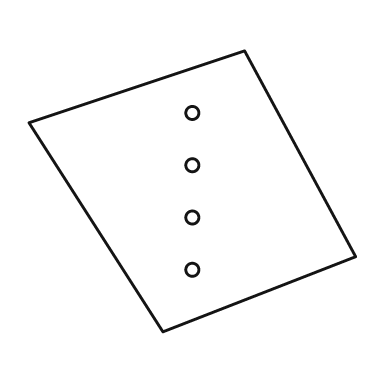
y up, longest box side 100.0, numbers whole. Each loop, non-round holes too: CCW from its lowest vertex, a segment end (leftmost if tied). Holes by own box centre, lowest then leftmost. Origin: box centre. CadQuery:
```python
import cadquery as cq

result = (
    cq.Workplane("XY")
    .moveTo(-9.0, -43.0)
    .lineTo(50.0, -20.0)
    .lineTo(16.0, 43.0)
    .lineTo(-50.0, 21.0)
    .close()
    .moveTo(0.0, -24.0)
    .circle(2.0)
    .moveTo(0.0, -8.0)
    .circle(2.0)
    .moveTo(0.0, 8.0)
    .circle(2.0)
    .moveTo(0.0, 24.0)
    .circle(2.0)
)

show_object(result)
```